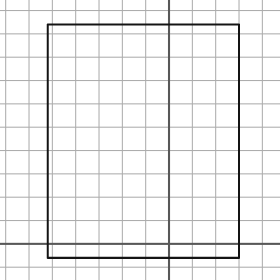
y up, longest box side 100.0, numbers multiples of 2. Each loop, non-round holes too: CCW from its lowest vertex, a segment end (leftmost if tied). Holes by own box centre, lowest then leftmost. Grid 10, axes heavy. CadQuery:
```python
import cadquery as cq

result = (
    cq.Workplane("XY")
    .moveTo(-52.0, -6.0)
    .lineTo(30.0, -6.0)
    .lineTo(30.0, 94.0)
    .lineTo(-52.0, 94.0)
    .close()
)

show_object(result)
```